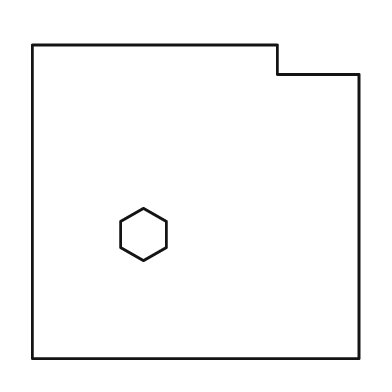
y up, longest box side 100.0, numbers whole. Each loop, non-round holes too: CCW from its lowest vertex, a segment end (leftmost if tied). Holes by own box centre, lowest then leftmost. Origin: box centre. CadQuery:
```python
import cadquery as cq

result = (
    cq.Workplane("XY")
    .moveTo(-50.0, -48.0)
    .lineTo(50.0, -48.0)
    .lineTo(50.0, 39.0)
    .lineTo(25.0, 39.0)
    .lineTo(25.0, 48.0)
    .lineTo(-50.0, 48.0)
    .close()
    .moveTo(-16.0, -18.0)
    .lineTo(-9.0, -14.0)
    .lineTo(-9.0, -6.0)
    .lineTo(-16.0, -2.0)
    .lineTo(-23.0, -6.0)
    .lineTo(-23.0, -14.0)
    .close()
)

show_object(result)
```